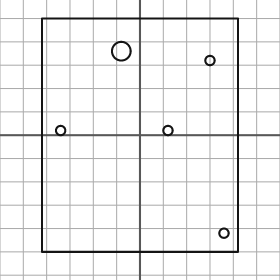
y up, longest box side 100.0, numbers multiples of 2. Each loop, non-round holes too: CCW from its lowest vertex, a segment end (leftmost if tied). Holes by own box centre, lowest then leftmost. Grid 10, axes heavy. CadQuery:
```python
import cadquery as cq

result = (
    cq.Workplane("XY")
    .moveTo(-42.0, -50.0)
    .lineTo(42.0, -50.0)
    .lineTo(42.0, 50.0)
    .lineTo(-42.0, 50.0)
    .close()
    .moveTo(36.0, -42.0)
    .circle(2.0)
    .moveTo(-34.0, 2.0)
    .circle(2.0)
    .moveTo(12.0, 2.0)
    .circle(2.0)
    .moveTo(30.0, 32.0)
    .circle(2.0)
    .moveTo(-8.0, 36.0)
    .circle(4.0)
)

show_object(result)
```